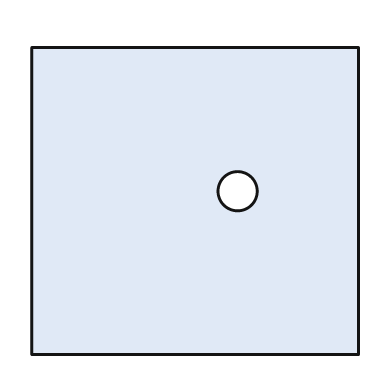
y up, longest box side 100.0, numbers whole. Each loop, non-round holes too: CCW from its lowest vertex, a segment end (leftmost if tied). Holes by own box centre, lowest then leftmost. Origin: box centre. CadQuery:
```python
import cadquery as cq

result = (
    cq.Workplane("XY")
    .moveTo(-50.0, -47.0)
    .lineTo(50.0, -47.0)
    .lineTo(50.0, 47.0)
    .lineTo(-50.0, 47.0)
    .close()
    .moveTo(13.0, 3.0)
    .circle(6.0)
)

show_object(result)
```